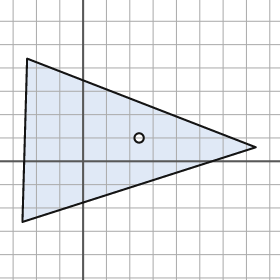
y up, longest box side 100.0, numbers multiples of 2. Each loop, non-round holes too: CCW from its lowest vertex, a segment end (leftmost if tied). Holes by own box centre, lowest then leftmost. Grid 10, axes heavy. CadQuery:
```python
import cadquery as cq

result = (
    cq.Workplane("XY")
    .moveTo(-26.0, -26.0)
    .lineTo(74.0, 6.0)
    .lineTo(-24.0, 44.0)
    .close()
    .moveTo(24.0, 10.0)
    .circle(2.0)
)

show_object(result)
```